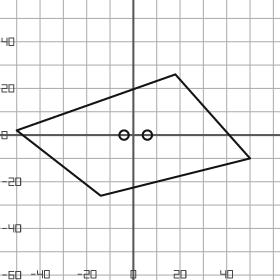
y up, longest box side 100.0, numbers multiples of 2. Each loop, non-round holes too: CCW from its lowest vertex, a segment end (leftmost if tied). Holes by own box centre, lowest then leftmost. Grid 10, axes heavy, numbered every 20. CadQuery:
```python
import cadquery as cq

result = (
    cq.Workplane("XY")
    .moveTo(-14.0, -26.0)
    .lineTo(50.0, -10.0)
    .lineTo(18.0, 26.0)
    .lineTo(-50.0, 2.0)
    .close()
    .moveTo(-4.0, 0.0)
    .circle(2.0)
    .moveTo(6.0, 0.0)
    .circle(2.0)
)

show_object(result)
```